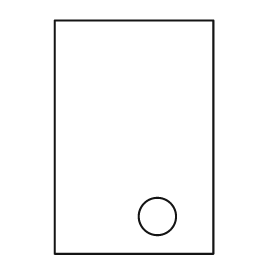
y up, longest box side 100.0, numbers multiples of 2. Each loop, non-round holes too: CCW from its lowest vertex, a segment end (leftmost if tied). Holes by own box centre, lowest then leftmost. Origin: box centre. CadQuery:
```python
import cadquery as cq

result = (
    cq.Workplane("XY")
    .moveTo(-34.0, -50.0)
    .lineTo(34.0, -50.0)
    .lineTo(34.0, 50.0)
    .lineTo(-34.0, 50.0)
    .close()
    .moveTo(10.0, -34.0)
    .circle(8.0)
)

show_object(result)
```